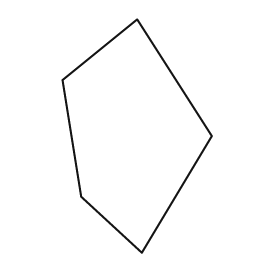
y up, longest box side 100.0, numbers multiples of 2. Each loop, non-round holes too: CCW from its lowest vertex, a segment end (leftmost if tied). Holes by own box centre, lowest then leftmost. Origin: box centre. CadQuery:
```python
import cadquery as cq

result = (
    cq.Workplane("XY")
    .moveTo(2.0, -50.0)
    .lineTo(32.0, 0.0)
    .lineTo(0.0, 50.0)
    .lineTo(-32.0, 24.0)
    .lineTo(-24.0, -26.0)
    .close()
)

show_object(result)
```